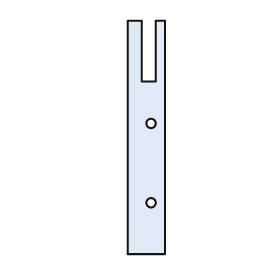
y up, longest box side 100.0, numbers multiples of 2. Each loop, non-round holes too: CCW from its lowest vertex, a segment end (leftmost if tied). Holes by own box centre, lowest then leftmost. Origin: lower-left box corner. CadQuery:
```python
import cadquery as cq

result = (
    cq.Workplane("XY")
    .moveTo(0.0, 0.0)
    .lineTo(16.0, 0.0)
    .lineTo(16.0, 100.0)
    .lineTo(12.0, 100.0)
    .lineTo(12.0, 74.0)
    .lineTo(6.0, 74.0)
    .lineTo(6.0, 100.0)
    .lineTo(0.0, 100.0)
    .close()
    .moveTo(10.0, 22.0)
    .circle(2.0)
    .moveTo(10.0, 56.0)
    .circle(2.0)
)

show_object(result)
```